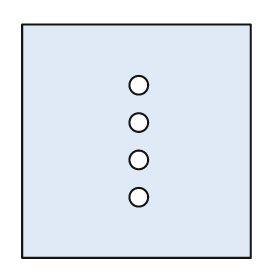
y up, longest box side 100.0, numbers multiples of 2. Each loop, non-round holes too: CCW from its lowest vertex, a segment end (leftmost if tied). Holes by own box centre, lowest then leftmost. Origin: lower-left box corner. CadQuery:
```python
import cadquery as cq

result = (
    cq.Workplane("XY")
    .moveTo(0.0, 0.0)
    .lineTo(98.0, 0.0)
    .lineTo(98.0, 100.0)
    .lineTo(0.0, 100.0)
    .close()
    .moveTo(50.0, 26.0)
    .circle(4.0)
    .moveTo(50.0, 42.0)
    .circle(4.0)
    .moveTo(50.0, 58.0)
    .circle(4.0)
    .moveTo(50.0, 74.0)
    .circle(4.0)
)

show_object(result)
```